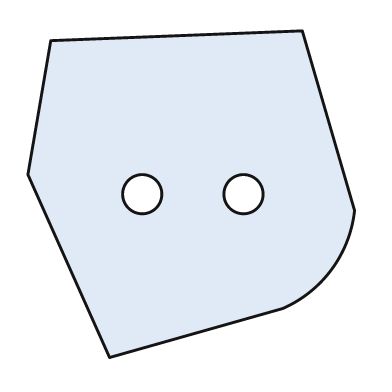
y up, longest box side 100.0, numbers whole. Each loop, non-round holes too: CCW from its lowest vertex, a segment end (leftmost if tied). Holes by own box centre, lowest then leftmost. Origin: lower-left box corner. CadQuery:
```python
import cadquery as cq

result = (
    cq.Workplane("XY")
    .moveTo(25.0, 0.0)
    .lineTo(78.0, 15.0)
    .threePointArc((93.0, 27.0), (100.0, 45.0))
    .lineTo(84.0, 100.0)
    .lineTo(7.0, 97.0)
    .lineTo(0.0, 56.0)
    .close()
    .moveTo(35.0, 50.0)
    .circle(6.0)
    .moveTo(66.0, 50.0)
    .circle(6.0)
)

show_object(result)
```